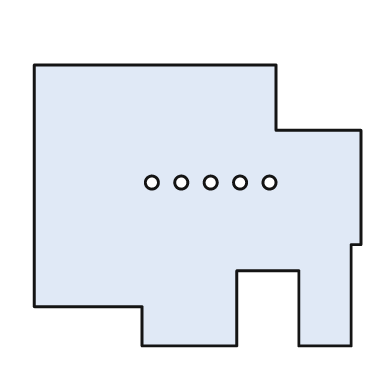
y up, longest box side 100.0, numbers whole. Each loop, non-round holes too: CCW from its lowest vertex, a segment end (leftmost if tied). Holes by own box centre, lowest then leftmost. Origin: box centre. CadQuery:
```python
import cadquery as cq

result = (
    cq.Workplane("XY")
    .moveTo(-17.0, -43.0)
    .lineTo(12.0, -43.0)
    .lineTo(12.0, -20.0)
    .lineTo(31.0, -20.0)
    .lineTo(31.0, -43.0)
    .lineTo(47.0, -43.0)
    .lineTo(47.0, -12.0)
    .lineTo(50.0, -12.0)
    .lineTo(50.0, 23.0)
    .lineTo(24.0, 23.0)
    .lineTo(24.0, 43.0)
    .lineTo(-50.0, 43.0)
    .lineTo(-50.0, -31.0)
    .lineTo(-17.0, -31.0)
    .close()
    .moveTo(-14.0, 7.0)
    .circle(2.0)
    .moveTo(-5.0, 7.0)
    .circle(2.0)
    .moveTo(4.0, 7.0)
    .circle(2.0)
    .moveTo(13.0, 7.0)
    .circle(2.0)
    .moveTo(22.0, 7.0)
    .circle(2.0)
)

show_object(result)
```